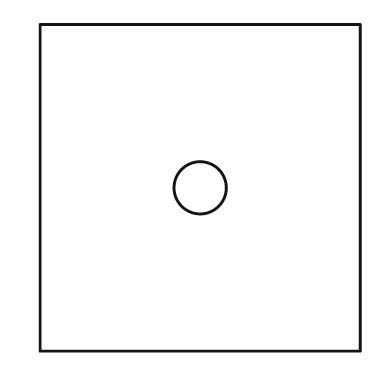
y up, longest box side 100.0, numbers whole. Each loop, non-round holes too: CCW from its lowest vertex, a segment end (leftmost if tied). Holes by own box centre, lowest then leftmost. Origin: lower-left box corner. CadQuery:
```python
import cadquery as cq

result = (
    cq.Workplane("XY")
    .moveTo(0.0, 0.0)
    .lineTo(98.0, 0.0)
    .lineTo(98.0, 100.0)
    .lineTo(0.0, 100.0)
    .close()
    .moveTo(49.0, 50.0)
    .circle(8.0)
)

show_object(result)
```